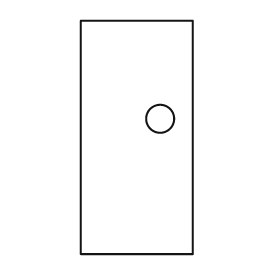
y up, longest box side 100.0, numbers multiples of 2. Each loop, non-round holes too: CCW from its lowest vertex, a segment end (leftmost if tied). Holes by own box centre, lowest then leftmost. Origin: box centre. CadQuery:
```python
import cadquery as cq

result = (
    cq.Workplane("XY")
    .moveTo(-24.0, -50.0)
    .lineTo(24.0, -50.0)
    .lineTo(24.0, 50.0)
    .lineTo(-24.0, 50.0)
    .close()
    .moveTo(10.0, 8.0)
    .circle(6.0)
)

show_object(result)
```